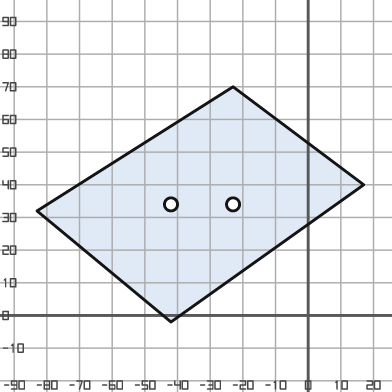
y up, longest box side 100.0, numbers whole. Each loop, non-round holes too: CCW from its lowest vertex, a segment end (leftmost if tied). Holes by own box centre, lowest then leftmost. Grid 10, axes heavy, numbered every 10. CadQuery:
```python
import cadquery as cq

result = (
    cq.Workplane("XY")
    .moveTo(-42.0, -2.0)
    .lineTo(17.0, 40.0)
    .lineTo(-23.0, 70.0)
    .lineTo(-83.0, 32.0)
    .close()
    .moveTo(-42.0, 34.0)
    .circle(2.0)
    .moveTo(-23.0, 34.0)
    .circle(2.0)
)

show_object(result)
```